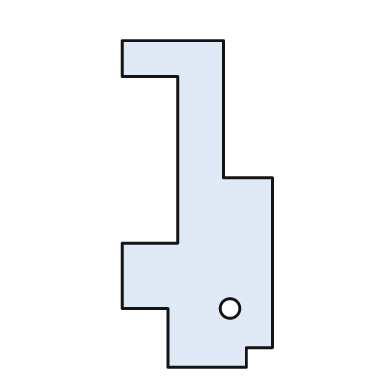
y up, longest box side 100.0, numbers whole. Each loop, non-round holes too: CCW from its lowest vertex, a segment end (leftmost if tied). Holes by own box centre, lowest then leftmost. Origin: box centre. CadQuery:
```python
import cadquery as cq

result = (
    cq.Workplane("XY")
    .moveTo(-9.0, -50.0)
    .lineTo(15.0, -50.0)
    .lineTo(15.0, -44.0)
    .lineTo(23.0, -44.0)
    .lineTo(23.0, 8.0)
    .lineTo(8.0, 8.0)
    .lineTo(8.0, 50.0)
    .lineTo(-23.0, 50.0)
    .lineTo(-23.0, 39.0)
    .lineTo(-6.0, 39.0)
    .lineTo(-6.0, -12.0)
    .lineTo(-23.0, -12.0)
    .lineTo(-23.0, -32.0)
    .lineTo(-9.0, -32.0)
    .close()
    .moveTo(10.0, -32.0)
    .circle(3.0)
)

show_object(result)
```